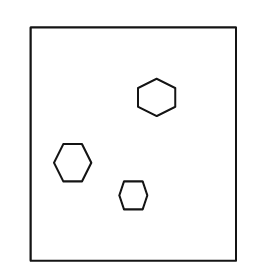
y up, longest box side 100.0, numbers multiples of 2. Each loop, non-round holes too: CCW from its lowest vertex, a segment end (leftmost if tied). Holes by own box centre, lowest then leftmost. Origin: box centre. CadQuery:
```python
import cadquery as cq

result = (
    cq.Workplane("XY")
    .moveTo(-44.0, -50.0)
    .lineTo(44.0, -50.0)
    .lineTo(44.0, 50.0)
    .lineTo(-44.0, 50.0)
    .close()
    .moveTo(-4.0, -28.0)
    .lineTo(4.0, -28.0)
    .lineTo(6.0, -22.0)
    .lineTo(4.0, -16.0)
    .lineTo(-4.0, -16.0)
    .lineTo(-6.0, -22.0)
    .close()
    .moveTo(-30.0, -16.0)
    .lineTo(-22.0, -16.0)
    .lineTo(-18.0, -8.0)
    .lineTo(-22.0, 0.0)
    .lineTo(-30.0, 0.0)
    .lineTo(-34.0, -8.0)
    .close()
    .moveTo(10.0, 12.0)
    .lineTo(18.0, 16.0)
    .lineTo(18.0, 24.0)
    .lineTo(10.0, 28.0)
    .lineTo(2.0, 24.0)
    .lineTo(2.0, 16.0)
    .close()
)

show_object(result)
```